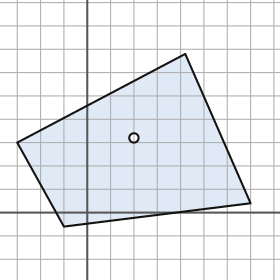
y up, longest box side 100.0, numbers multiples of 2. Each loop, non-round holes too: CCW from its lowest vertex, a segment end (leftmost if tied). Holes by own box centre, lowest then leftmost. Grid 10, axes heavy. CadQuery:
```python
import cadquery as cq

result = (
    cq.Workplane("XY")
    .moveTo(-10.0, -6.0)
    .lineTo(70.0, 4.0)
    .lineTo(42.0, 68.0)
    .lineTo(-30.0, 30.0)
    .close()
    .moveTo(20.0, 32.0)
    .circle(2.0)
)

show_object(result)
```